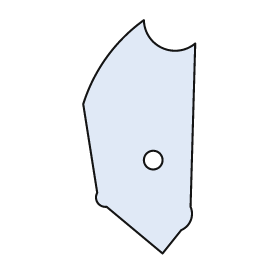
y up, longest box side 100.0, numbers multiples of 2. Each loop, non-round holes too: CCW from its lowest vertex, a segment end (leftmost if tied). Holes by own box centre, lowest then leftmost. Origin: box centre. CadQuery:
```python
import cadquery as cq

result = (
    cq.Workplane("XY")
    .moveTo(10.0, -50.0)
    .lineTo(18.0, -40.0)
    .threePointArc((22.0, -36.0), (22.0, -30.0))
    .lineTo(24.0, 40.0)
    .threePointArc((10.0, 38.0), (2.0, 50.0))
    .threePointArc((-14.0, 34.0), (-24.0, 14.0))
    .lineTo(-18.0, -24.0)
    .threePointArc((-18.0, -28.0), (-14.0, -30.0))
    .close()
    .moveTo(6.0, -10.0)
    .circle(4.0)
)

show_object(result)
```